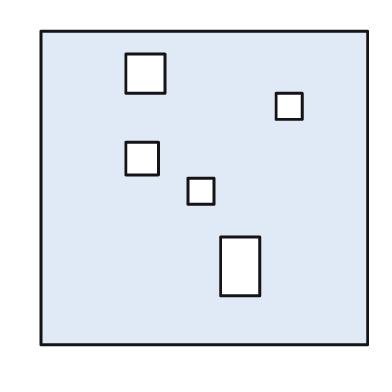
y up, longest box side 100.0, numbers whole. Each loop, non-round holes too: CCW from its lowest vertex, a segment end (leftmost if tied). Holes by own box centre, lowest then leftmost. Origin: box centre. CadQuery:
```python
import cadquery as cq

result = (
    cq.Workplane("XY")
    .moveTo(-50.0, -48.0)
    .lineTo(50.0, -48.0)
    .lineTo(50.0, 48.0)
    .lineTo(-50.0, 48.0)
    .close()
    .moveTo(5.0, -33.0)
    .lineTo(17.0, -33.0)
    .lineTo(17.0, -15.0)
    .lineTo(5.0, -15.0)
    .close()
    .moveTo(-5.0, -5.0)
    .lineTo(3.0, -5.0)
    .lineTo(3.0, 3.0)
    .lineTo(-5.0, 3.0)
    .close()
    .moveTo(-24.0, 4.0)
    .lineTo(-14.0, 4.0)
    .lineTo(-14.0, 14.0)
    .lineTo(-24.0, 14.0)
    .close()
    .moveTo(22.0, 21.0)
    .lineTo(30.0, 21.0)
    .lineTo(30.0, 29.0)
    .lineTo(22.0, 29.0)
    .close()
    .moveTo(-24.0, 29.0)
    .lineTo(-12.0, 29.0)
    .lineTo(-12.0, 41.0)
    .lineTo(-24.0, 41.0)
    .close()
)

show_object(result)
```